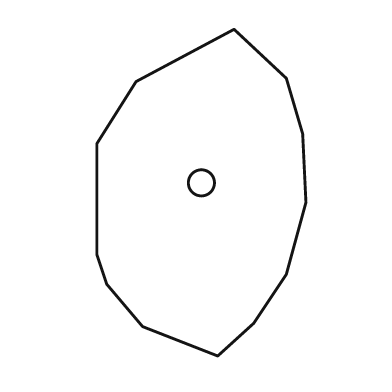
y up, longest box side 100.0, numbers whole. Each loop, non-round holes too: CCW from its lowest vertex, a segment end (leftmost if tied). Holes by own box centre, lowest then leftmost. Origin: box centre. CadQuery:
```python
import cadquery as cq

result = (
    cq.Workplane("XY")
    .moveTo(5.0, -50.0)
    .lineTo(16.0, -40.0)
    .lineTo(26.0, -25.0)
    .lineTo(32.0, -3.0)
    .lineTo(31.0, 18.0)
    .lineTo(26.0, 35.0)
    .lineTo(10.0, 50.0)
    .lineTo(-20.0, 34.0)
    .lineTo(-32.0, 15.0)
    .lineTo(-32.0, -19.0)
    .lineTo(-29.0, -28.0)
    .lineTo(-18.0, -41.0)
    .close()
    .moveTo(0.0, 3.0)
    .circle(4.0)
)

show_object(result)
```